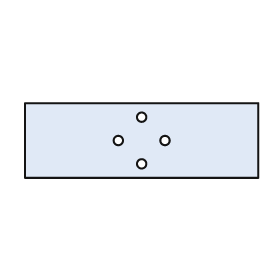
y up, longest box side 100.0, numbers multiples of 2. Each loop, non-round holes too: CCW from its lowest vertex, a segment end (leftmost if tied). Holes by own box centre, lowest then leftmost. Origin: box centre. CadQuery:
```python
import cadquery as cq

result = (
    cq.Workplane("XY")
    .moveTo(-50.0, -16.0)
    .lineTo(50.0, -16.0)
    .lineTo(50.0, 16.0)
    .lineTo(-50.0, 16.0)
    .close()
    .moveTo(0.0, -10.0)
    .circle(2.0)
    .moveTo(-10.0, 0.0)
    .circle(2.0)
    .moveTo(10.0, 0.0)
    .circle(2.0)
    .moveTo(0.0, 10.0)
    .circle(2.0)
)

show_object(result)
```